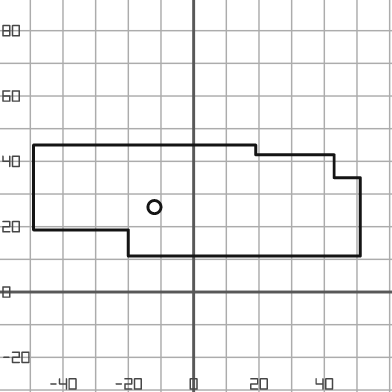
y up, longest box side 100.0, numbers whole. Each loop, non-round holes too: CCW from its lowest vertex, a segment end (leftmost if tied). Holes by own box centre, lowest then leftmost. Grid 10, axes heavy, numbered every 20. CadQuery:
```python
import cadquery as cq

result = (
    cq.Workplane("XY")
    .moveTo(-20.0, 11.0)
    .lineTo(51.0, 11.0)
    .lineTo(51.0, 35.0)
    .lineTo(43.0, 35.0)
    .lineTo(43.0, 42.0)
    .lineTo(19.0, 42.0)
    .lineTo(19.0, 45.0)
    .lineTo(-49.0, 45.0)
    .lineTo(-49.0, 19.0)
    .lineTo(-20.0, 19.0)
    .close()
    .moveTo(-12.0, 26.0)
    .circle(2.0)
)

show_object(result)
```